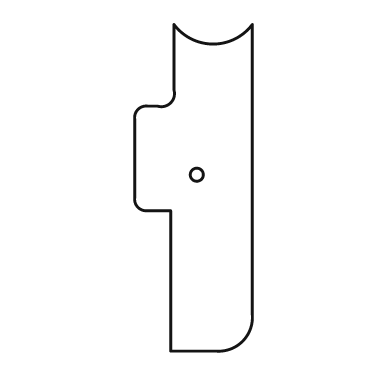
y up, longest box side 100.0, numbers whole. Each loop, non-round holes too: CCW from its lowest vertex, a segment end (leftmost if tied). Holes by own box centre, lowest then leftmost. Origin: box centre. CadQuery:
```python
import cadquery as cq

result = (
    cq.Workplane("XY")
    .moveTo(-7.0, -50.0)
    .lineTo(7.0, -50.0)
    .threePointArc((15.0, -47.0), (18.0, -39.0))
    .lineTo(18.0, 50.0)
    .threePointArc((6.0, 44.0), (-6.0, 50.0))
    .lineTo(-6.0, 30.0)
    .threePointArc((-7.0, 26.0), (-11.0, 25.0))
    .lineTo(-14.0, 25.0)
    .threePointArc((-17.0, 24.0), (-18.0, 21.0))
    .lineTo(-18.0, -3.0)
    .threePointArc((-17.0, -6.0), (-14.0, -7.0))
    .lineTo(-7.0, -7.0)
    .close()
    .moveTo(1.0, 4.0)
    .circle(2.0)
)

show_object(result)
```